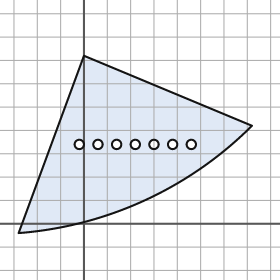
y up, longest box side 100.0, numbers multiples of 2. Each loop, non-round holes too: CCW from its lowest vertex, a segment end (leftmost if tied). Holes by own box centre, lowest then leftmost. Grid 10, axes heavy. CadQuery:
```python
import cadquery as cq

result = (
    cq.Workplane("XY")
    .moveTo(-28.0, -4.0)
    .threePointArc((26.0, 10.0), (72.0, 42.0))
    .lineTo(0.0, 72.0)
    .close()
    .moveTo(-2.0, 34.0)
    .circle(2.0)
    .moveTo(6.0, 34.0)
    .circle(2.0)
    .moveTo(14.0, 34.0)
    .circle(2.0)
    .moveTo(22.0, 34.0)
    .circle(2.0)
    .moveTo(30.0, 34.0)
    .circle(2.0)
    .moveTo(38.0, 34.0)
    .circle(2.0)
    .moveTo(46.0, 34.0)
    .circle(2.0)
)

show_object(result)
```